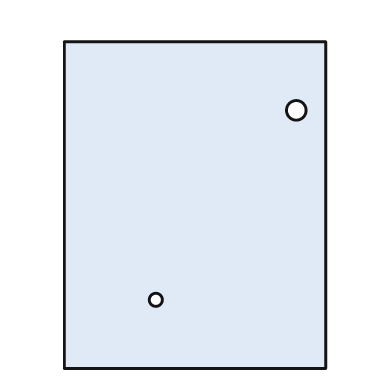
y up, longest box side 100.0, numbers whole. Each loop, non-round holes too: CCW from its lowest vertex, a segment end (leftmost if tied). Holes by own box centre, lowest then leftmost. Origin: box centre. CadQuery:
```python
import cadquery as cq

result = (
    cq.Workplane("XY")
    .moveTo(-40.0, -50.0)
    .lineTo(40.0, -50.0)
    .lineTo(40.0, 50.0)
    .lineTo(-40.0, 50.0)
    .close()
    .moveTo(-12.0, -29.0)
    .circle(2.0)
    .moveTo(31.0, 29.0)
    .circle(3.0)
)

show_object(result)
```